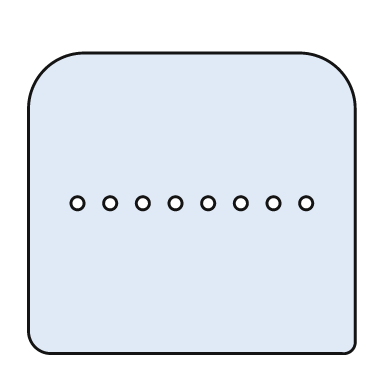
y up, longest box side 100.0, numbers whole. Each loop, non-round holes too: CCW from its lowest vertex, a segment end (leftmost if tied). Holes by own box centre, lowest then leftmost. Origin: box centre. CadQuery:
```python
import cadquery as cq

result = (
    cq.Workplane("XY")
    .moveTo(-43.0, -46.0)
    .lineTo(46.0, -46.0)
    .threePointArc((49.0, -45.0), (50.0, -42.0))
    .lineTo(50.0, 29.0)
    .threePointArc((45.0, 41.0), (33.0, 46.0))
    .lineTo(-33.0, 46.0)
    .threePointArc((-45.0, 41.0), (-50.0, 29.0))
    .lineTo(-50.0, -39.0)
    .threePointArc((-48.0, -44.0), (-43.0, -46.0))
    .close()
    .moveTo(-35.0, 0.0)
    .circle(2.0)
    .moveTo(-25.0, 0.0)
    .circle(2.0)
    .moveTo(-15.0, 0.0)
    .circle(2.0)
    .moveTo(-5.0, 0.0)
    .circle(2.0)
    .moveTo(5.0, 0.0)
    .circle(2.0)
    .moveTo(15.0, 0.0)
    .circle(2.0)
    .moveTo(25.0, 0.0)
    .circle(2.0)
    .moveTo(35.0, 0.0)
    .circle(2.0)
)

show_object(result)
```